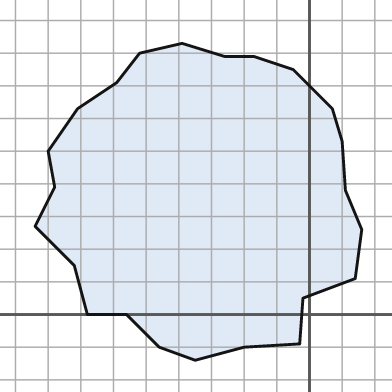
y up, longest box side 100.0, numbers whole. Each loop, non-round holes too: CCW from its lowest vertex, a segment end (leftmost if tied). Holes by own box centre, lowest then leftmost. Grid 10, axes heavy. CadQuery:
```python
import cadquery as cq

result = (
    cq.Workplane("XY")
    .moveTo(-35.0, -14.0)
    .lineTo(-20.0, -10.0)
    .lineTo(-3.0, -9.0)
    .lineTo(-2.0, 5.0)
    .lineTo(14.0, 11.0)
    .lineTo(16.0, 26.0)
    .lineTo(11.0, 38.0)
    .lineTo(10.0, 53.0)
    .lineTo(7.0, 63.0)
    .lineTo(-5.0, 75.0)
    .lineTo(-17.0, 79.0)
    .lineTo(-26.0, 79.0)
    .lineTo(-39.0, 83.0)
    .lineTo(-52.0, 80.0)
    .lineTo(-59.0, 71.0)
    .lineTo(-71.0, 63.0)
    .lineTo(-80.0, 50.0)
    .lineTo(-78.0, 39.0)
    .lineTo(-84.0, 27.0)
    .lineTo(-72.0, 15.0)
    .lineTo(-68.0, 0.0)
    .lineTo(-56.0, 0.0)
    .lineTo(-46.0, -10.0)
    .close()
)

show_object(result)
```